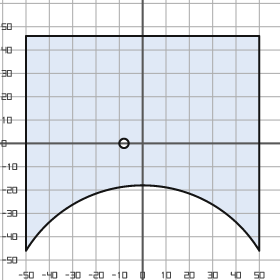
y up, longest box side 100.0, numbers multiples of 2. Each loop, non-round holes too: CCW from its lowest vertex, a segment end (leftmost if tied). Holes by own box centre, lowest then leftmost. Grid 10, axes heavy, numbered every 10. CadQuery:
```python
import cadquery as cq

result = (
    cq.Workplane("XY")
    .moveTo(-50.0, -46.0)
    .threePointArc((0.0, -18.0), (50.0, -46.0))
    .lineTo(50.0, 46.0)
    .lineTo(-50.0, 46.0)
    .close()
    .moveTo(-8.0, 0.0)
    .circle(2.0)
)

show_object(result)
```